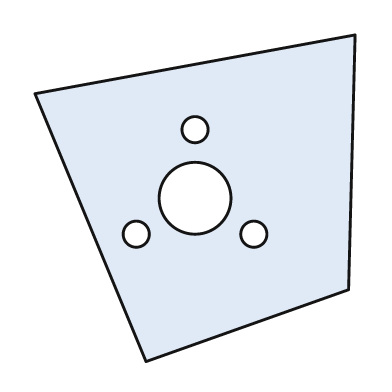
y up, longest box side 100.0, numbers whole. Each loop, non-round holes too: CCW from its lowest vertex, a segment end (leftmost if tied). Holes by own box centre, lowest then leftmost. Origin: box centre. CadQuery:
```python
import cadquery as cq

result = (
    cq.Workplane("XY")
    .moveTo(-15.0, -50.0)
    .lineTo(47.0, -28.0)
    .lineTo(49.0, 50.0)
    .lineTo(-49.0, 32.0)
    .close()
    .moveTo(-18.0, -11.0)
    .circle(4.0)
    .moveTo(18.0, -11.0)
    .circle(4.0)
    .moveTo(0.0, 0.0)
    .circle(11.0)
    .moveTo(0.0, 21.0)
    .circle(4.0)
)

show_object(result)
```